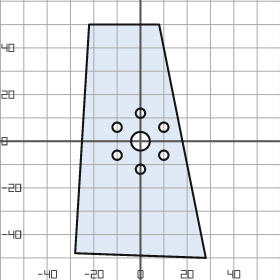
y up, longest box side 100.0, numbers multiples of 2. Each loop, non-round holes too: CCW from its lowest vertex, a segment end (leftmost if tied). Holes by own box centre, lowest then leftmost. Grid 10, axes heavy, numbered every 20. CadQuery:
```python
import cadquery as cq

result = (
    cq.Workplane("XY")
    .moveTo(28.0, -50.0)
    .lineTo(8.0, 50.0)
    .lineTo(-22.0, 50.0)
    .lineTo(-28.0, -48.0)
    .close()
    .moveTo(0.0, -12.0)
    .circle(2.0)
    .moveTo(-10.0, -6.0)
    .circle(2.0)
    .moveTo(10.0, -6.0)
    .circle(2.0)
    .moveTo(0.0, 0.0)
    .circle(4.0)
    .moveTo(-10.0, 6.0)
    .circle(2.0)
    .moveTo(10.0, 6.0)
    .circle(2.0)
    .moveTo(0.0, 12.0)
    .circle(2.0)
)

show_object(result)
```